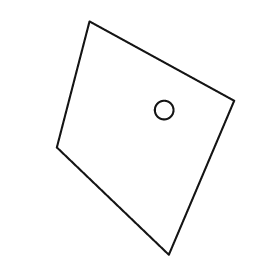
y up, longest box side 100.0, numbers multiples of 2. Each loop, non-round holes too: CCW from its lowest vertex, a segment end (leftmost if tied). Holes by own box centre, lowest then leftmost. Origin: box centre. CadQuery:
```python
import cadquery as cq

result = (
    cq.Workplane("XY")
    .moveTo(10.0, -50.0)
    .lineTo(38.0, 16.0)
    .lineTo(-24.0, 50.0)
    .lineTo(-38.0, -4.0)
    .close()
    .moveTo(8.0, 12.0)
    .circle(4.0)
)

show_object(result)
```